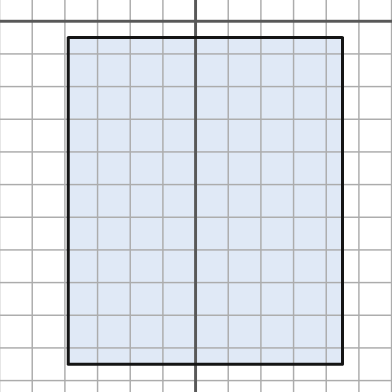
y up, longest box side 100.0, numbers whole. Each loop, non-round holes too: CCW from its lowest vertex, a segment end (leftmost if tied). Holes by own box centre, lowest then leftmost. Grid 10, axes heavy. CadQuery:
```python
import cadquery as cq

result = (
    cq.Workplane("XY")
    .moveTo(-39.0, -105.0)
    .lineTo(45.0, -105.0)
    .lineTo(45.0, -5.0)
    .lineTo(-39.0, -5.0)
    .close()
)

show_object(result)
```